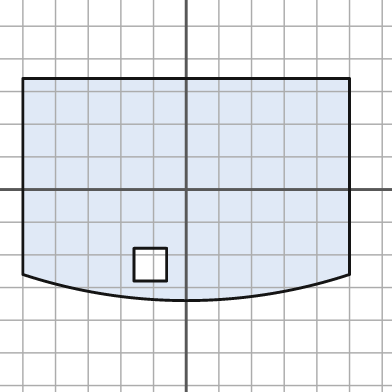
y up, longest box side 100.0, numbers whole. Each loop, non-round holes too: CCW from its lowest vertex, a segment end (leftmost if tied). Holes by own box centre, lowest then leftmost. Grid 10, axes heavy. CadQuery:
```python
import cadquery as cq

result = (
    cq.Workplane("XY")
    .moveTo(-50.0, -26.0)
    .threePointArc((0.0, -34.0), (50.0, -26.0))
    .lineTo(50.0, 34.0)
    .lineTo(-50.0, 34.0)
    .close()
    .moveTo(-16.0, -28.0)
    .lineTo(-6.0, -28.0)
    .lineTo(-6.0, -18.0)
    .lineTo(-16.0, -18.0)
    .close()
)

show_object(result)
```